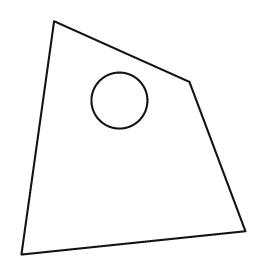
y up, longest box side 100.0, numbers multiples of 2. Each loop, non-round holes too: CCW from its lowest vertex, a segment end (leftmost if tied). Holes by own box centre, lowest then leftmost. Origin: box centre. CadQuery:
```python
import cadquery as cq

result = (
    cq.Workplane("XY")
    .moveTo(-48.0, -50.0)
    .lineTo(48.0, -40.0)
    .lineTo(24.0, 24.0)
    .lineTo(-34.0, 50.0)
    .close()
    .moveTo(-6.0, 16.0)
    .circle(12.0)
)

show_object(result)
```